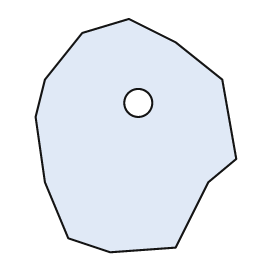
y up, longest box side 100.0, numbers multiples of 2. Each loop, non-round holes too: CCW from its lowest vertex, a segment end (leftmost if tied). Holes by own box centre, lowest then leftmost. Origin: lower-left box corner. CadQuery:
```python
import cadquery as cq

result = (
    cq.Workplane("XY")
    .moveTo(32.0, 0.0)
    .lineTo(60.0, 2.0)
    .lineTo(74.0, 30.0)
    .lineTo(86.0, 40.0)
    .lineTo(80.0, 74.0)
    .lineTo(60.0, 90.0)
    .lineTo(40.0, 100.0)
    .lineTo(20.0, 94.0)
    .lineTo(4.0, 74.0)
    .lineTo(0.0, 58.0)
    .lineTo(4.0, 30.0)
    .lineTo(14.0, 6.0)
    .close()
    .moveTo(44.0, 64.0)
    .circle(6.0)
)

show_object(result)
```